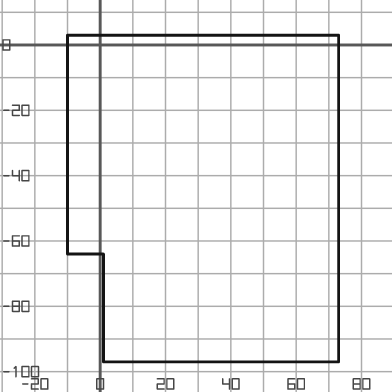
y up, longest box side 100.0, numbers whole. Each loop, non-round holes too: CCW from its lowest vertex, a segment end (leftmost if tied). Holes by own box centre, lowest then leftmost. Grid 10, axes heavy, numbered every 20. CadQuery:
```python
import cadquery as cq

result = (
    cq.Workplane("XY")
    .moveTo(1.0, -97.0)
    .lineTo(73.0, -97.0)
    .lineTo(73.0, 3.0)
    .lineTo(-10.0, 3.0)
    .lineTo(-10.0, -64.0)
    .lineTo(1.0, -64.0)
    .close()
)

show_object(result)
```